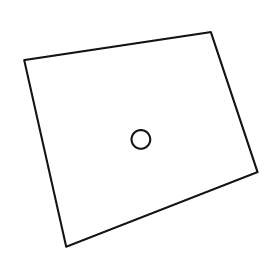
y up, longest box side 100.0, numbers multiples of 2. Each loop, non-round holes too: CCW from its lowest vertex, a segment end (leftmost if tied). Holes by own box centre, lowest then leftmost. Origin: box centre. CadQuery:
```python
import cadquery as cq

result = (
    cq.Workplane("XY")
    .moveTo(-32.0, -46.0)
    .lineTo(50.0, -14.0)
    .lineTo(30.0, 46.0)
    .lineTo(-50.0, 34.0)
    .close()
    .moveTo(0.0, 0.0)
    .circle(4.0)
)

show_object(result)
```